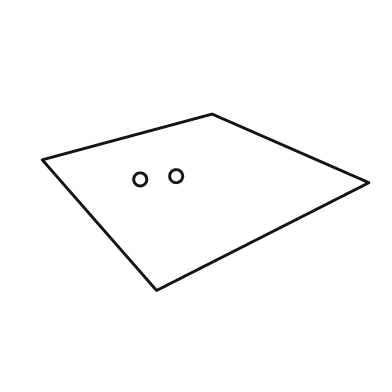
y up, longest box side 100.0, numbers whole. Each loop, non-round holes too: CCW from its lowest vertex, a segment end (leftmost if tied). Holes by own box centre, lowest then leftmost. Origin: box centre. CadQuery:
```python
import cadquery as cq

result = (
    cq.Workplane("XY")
    .moveTo(-15.0, -27.0)
    .lineTo(50.0, 6.0)
    .lineTo(2.0, 27.0)
    .lineTo(-50.0, 13.0)
    .close()
    .moveTo(-20.0, 7.0)
    .circle(2.0)
    .moveTo(-9.0, 8.0)
    .circle(2.0)
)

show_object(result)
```